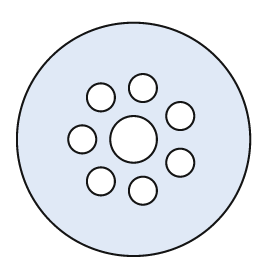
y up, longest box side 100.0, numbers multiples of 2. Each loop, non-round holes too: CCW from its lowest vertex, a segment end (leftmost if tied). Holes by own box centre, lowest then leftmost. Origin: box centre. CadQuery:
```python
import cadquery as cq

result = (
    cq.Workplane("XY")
    .moveTo(0.0, 0.0)
    .circle(50.0)
    .moveTo(4.0, -22.0)
    .circle(6.0)
    .moveTo(-14.0, -18.0)
    .circle(6.0)
    .moveTo(20.0, -10.0)
    .circle(6.0)
    .moveTo(-22.0, 0.0)
    .circle(6.0)
    .moveTo(0.0, 0.0)
    .circle(10.0)
    .moveTo(20.0, 10.0)
    .circle(6.0)
    .moveTo(-14.0, 18.0)
    .circle(6.0)
    .moveTo(4.0, 22.0)
    .circle(6.0)
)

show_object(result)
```